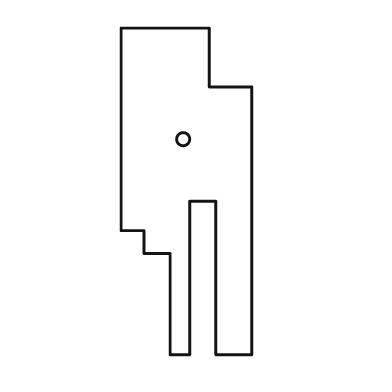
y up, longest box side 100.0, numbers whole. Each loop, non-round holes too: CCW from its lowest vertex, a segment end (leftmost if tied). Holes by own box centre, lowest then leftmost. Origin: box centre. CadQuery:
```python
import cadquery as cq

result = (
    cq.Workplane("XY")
    .moveTo(-5.0, -50.0)
    .lineTo(1.0, -50.0)
    .lineTo(1.0, -3.0)
    .lineTo(9.0, -3.0)
    .lineTo(9.0, -50.0)
    .lineTo(20.0, -50.0)
    .lineTo(20.0, 32.0)
    .lineTo(7.0, 32.0)
    .lineTo(7.0, 50.0)
    .lineTo(-20.0, 50.0)
    .lineTo(-20.0, -12.0)
    .lineTo(-13.0, -12.0)
    .lineTo(-13.0, -19.0)
    .lineTo(-5.0, -19.0)
    .close()
    .moveTo(-1.0, 16.0)
    .circle(2.0)
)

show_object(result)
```